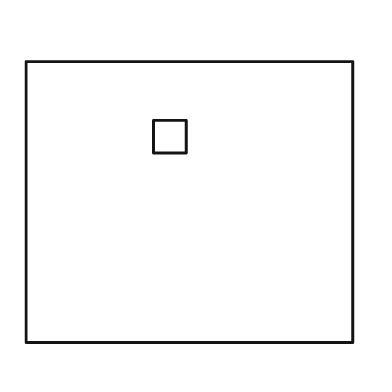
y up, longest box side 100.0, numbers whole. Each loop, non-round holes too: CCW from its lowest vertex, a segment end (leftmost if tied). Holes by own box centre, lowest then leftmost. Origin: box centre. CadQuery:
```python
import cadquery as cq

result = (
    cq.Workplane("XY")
    .moveTo(-50.0, -43.0)
    .lineTo(50.0, -43.0)
    .lineTo(50.0, 43.0)
    .lineTo(-50.0, 43.0)
    .close()
    .moveTo(-11.0, 15.0)
    .lineTo(-1.0, 15.0)
    .lineTo(-1.0, 25.0)
    .lineTo(-11.0, 25.0)
    .close()
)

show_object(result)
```